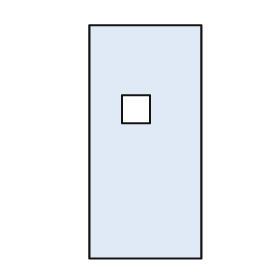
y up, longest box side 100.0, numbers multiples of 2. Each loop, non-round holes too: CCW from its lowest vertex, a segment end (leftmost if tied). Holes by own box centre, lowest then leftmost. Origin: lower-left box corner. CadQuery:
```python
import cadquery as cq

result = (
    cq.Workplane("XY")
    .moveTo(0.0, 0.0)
    .lineTo(48.0, 0.0)
    .lineTo(48.0, 100.0)
    .lineTo(0.0, 100.0)
    .close()
    .moveTo(14.0, 58.0)
    .lineTo(26.0, 58.0)
    .lineTo(26.0, 70.0)
    .lineTo(14.0, 70.0)
    .close()
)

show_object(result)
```